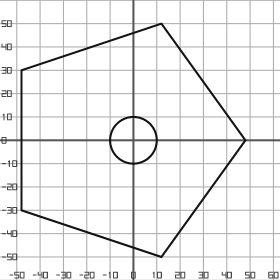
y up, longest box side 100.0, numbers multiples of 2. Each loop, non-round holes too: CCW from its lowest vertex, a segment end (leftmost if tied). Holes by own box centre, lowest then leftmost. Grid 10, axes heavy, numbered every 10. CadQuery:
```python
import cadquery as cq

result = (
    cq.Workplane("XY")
    .moveTo(12.0, -50.0)
    .lineTo(48.0, 0.0)
    .lineTo(12.0, 50.0)
    .lineTo(-48.0, 30.0)
    .lineTo(-48.0, -30.0)
    .close()
    .moveTo(0.0, 0.0)
    .circle(10.0)
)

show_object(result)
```